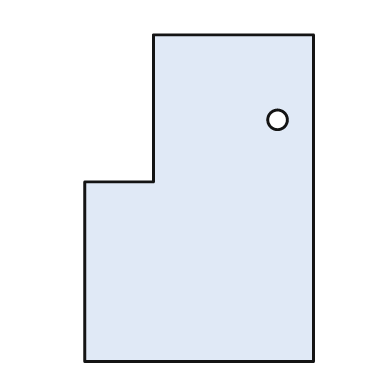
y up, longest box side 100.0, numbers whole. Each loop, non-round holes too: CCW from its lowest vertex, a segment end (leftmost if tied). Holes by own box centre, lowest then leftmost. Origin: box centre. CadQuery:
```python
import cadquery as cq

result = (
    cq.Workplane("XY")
    .moveTo(-35.0, -50.0)
    .lineTo(35.0, -50.0)
    .lineTo(35.0, 50.0)
    .lineTo(-14.0, 50.0)
    .lineTo(-14.0, 5.0)
    .lineTo(-35.0, 5.0)
    .close()
    .moveTo(24.0, 24.0)
    .circle(3.0)
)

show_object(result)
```